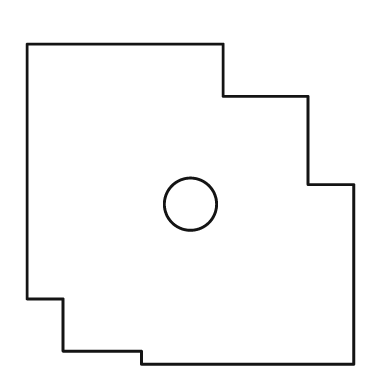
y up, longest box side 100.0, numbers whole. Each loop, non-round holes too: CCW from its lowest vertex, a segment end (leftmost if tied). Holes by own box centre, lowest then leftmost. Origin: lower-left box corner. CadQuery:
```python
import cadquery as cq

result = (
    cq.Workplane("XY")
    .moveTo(35.0, 0.0)
    .lineTo(100.0, 0.0)
    .lineTo(100.0, 55.0)
    .lineTo(86.0, 55.0)
    .lineTo(86.0, 82.0)
    .lineTo(60.0, 82.0)
    .lineTo(60.0, 98.0)
    .lineTo(0.0, 98.0)
    .lineTo(0.0, 20.0)
    .lineTo(11.0, 20.0)
    .lineTo(11.0, 4.0)
    .lineTo(35.0, 4.0)
    .close()
    .moveTo(50.0, 49.0)
    .circle(8.0)
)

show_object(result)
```